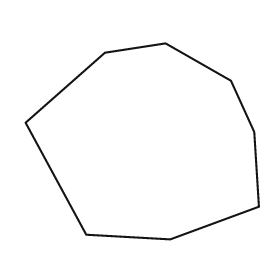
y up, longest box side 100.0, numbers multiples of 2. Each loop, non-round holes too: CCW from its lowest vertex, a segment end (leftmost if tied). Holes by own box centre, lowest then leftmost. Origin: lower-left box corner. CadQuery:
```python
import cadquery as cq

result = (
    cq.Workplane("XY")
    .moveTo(62.0, 0.0)
    .lineTo(100.0, 14.0)
    .lineTo(98.0, 46.0)
    .lineTo(88.0, 68.0)
    .lineTo(60.0, 84.0)
    .lineTo(34.0, 80.0)
    .lineTo(0.0, 50.0)
    .lineTo(26.0, 2.0)
    .close()
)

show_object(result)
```